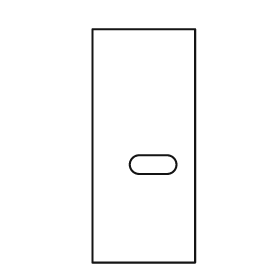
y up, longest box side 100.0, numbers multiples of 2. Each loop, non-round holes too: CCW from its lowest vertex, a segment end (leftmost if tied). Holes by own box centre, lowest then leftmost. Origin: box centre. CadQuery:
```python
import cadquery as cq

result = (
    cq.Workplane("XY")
    .moveTo(-22.0, -50.0)
    .lineTo(22.0, -50.0)
    .lineTo(22.0, 50.0)
    .lineTo(-22.0, 50.0)
    .close()
    .moveTo(-2.0, -12.0)
    .lineTo(10.0, -12.0)
    .threePointArc((14.0, -8.0), (10.0, -4.0))
    .lineTo(-2.0, -4.0)
    .threePointArc((-6.0, -8.0), (-2.0, -12.0))
    .close()
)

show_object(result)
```